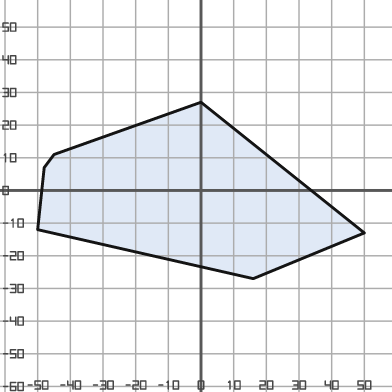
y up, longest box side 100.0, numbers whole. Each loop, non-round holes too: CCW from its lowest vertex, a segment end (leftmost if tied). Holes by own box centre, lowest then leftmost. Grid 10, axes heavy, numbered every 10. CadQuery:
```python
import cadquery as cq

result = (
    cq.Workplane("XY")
    .moveTo(16.0, -27.0)
    .lineTo(50.0, -13.0)
    .lineTo(0.0, 27.0)
    .lineTo(-45.0, 11.0)
    .lineTo(-48.0, 7.0)
    .lineTo(-50.0, -12.0)
    .close()
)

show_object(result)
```